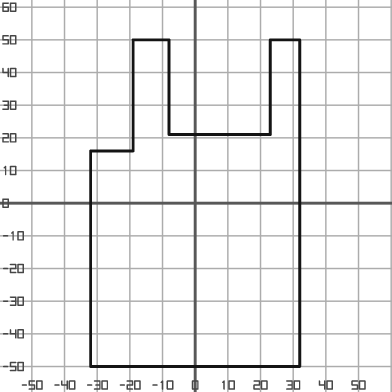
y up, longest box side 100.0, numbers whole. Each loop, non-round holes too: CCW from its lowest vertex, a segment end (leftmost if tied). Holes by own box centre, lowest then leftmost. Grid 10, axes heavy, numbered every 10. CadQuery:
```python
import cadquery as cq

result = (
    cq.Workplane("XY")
    .moveTo(-32.0, -50.0)
    .lineTo(32.0, -50.0)
    .lineTo(32.0, 50.0)
    .lineTo(23.0, 50.0)
    .lineTo(23.0, 21.0)
    .lineTo(-8.0, 21.0)
    .lineTo(-8.0, 50.0)
    .lineTo(-19.0, 50.0)
    .lineTo(-19.0, 16.0)
    .lineTo(-32.0, 16.0)
    .close()
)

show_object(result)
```